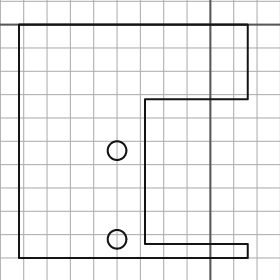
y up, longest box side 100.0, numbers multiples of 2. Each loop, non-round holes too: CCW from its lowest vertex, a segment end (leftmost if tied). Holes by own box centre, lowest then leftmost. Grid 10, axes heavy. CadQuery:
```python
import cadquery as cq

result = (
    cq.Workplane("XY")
    .moveTo(-82.0, -100.0)
    .lineTo(16.0, -100.0)
    .lineTo(16.0, -94.0)
    .lineTo(-28.0, -94.0)
    .lineTo(-28.0, -32.0)
    .lineTo(16.0, -32.0)
    .lineTo(16.0, 0.0)
    .lineTo(-82.0, 0.0)
    .close()
    .moveTo(-40.0, -92.0)
    .circle(4.0)
    .moveTo(-40.0, -54.0)
    .circle(4.0)
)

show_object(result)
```